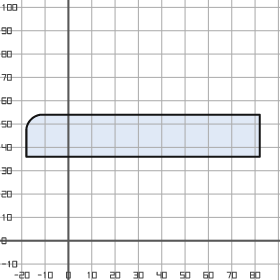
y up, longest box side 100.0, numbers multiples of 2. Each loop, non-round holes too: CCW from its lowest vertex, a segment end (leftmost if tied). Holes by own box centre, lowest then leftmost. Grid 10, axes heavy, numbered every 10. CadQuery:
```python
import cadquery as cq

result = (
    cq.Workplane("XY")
    .moveTo(-18.0, 36.0)
    .lineTo(82.0, 36.0)
    .lineTo(82.0, 54.0)
    .lineTo(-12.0, 54.0)
    .threePointArc((-16.0, 52.0), (-18.0, 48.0))
    .close()
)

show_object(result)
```